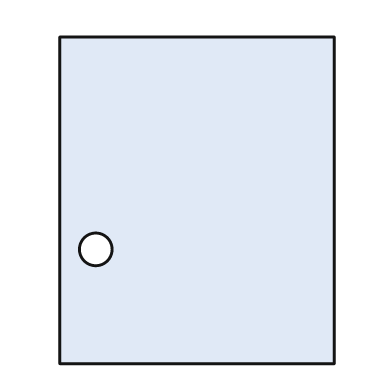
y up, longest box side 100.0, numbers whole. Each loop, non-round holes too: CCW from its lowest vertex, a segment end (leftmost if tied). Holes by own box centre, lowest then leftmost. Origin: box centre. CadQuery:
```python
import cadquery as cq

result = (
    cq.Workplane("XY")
    .moveTo(-42.0, -50.0)
    .lineTo(42.0, -50.0)
    .lineTo(42.0, 50.0)
    .lineTo(-42.0, 50.0)
    .close()
    .moveTo(-31.0, -15.0)
    .circle(5.0)
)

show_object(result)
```